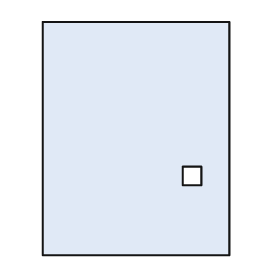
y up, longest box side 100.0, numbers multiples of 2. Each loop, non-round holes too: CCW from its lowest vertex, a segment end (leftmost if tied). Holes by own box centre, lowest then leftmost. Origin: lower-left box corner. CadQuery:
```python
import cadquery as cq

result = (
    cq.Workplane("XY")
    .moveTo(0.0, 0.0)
    .lineTo(80.0, 0.0)
    .lineTo(80.0, 100.0)
    .lineTo(0.0, 100.0)
    .close()
    .moveTo(60.0, 30.0)
    .lineTo(68.0, 30.0)
    .lineTo(68.0, 38.0)
    .lineTo(60.0, 38.0)
    .close()
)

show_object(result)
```